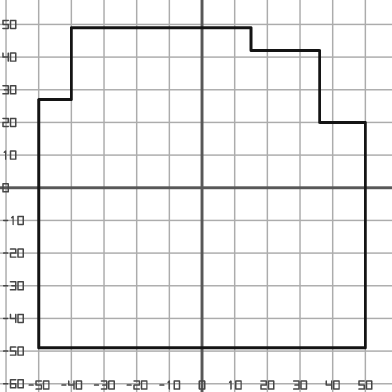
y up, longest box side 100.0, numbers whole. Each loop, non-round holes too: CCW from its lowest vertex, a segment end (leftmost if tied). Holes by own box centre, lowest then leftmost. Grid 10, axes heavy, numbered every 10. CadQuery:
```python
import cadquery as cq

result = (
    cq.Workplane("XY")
    .moveTo(-50.0, -49.0)
    .lineTo(50.0, -49.0)
    .lineTo(50.0, 20.0)
    .lineTo(36.0, 20.0)
    .lineTo(36.0, 42.0)
    .lineTo(15.0, 42.0)
    .lineTo(15.0, 49.0)
    .lineTo(-40.0, 49.0)
    .lineTo(-40.0, 27.0)
    .lineTo(-50.0, 27.0)
    .close()
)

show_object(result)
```